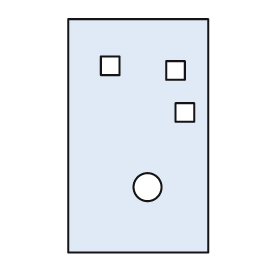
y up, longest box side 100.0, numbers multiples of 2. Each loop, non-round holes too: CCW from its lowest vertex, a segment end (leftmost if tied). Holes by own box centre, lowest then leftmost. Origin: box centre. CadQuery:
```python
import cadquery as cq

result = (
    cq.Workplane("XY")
    .moveTo(-30.0, -50.0)
    .lineTo(30.0, -50.0)
    .lineTo(30.0, 50.0)
    .lineTo(-30.0, 50.0)
    .close()
    .moveTo(4.0, -22.0)
    .circle(6.0)
    .moveTo(16.0, 6.0)
    .lineTo(24.0, 6.0)
    .lineTo(24.0, 14.0)
    .lineTo(16.0, 14.0)
    .close()
    .moveTo(12.0, 24.0)
    .lineTo(20.0, 24.0)
    .lineTo(20.0, 32.0)
    .lineTo(12.0, 32.0)
    .close()
    .moveTo(-16.0, 26.0)
    .lineTo(-8.0, 26.0)
    .lineTo(-8.0, 34.0)
    .lineTo(-16.0, 34.0)
    .close()
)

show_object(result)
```